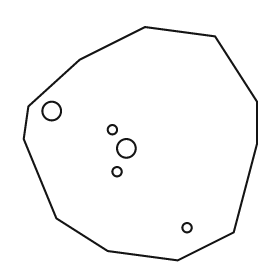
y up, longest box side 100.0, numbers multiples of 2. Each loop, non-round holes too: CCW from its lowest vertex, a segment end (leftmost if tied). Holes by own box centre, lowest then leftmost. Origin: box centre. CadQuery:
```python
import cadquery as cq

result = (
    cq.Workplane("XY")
    .moveTo(16.0, -50.0)
    .lineTo(40.0, -38.0)
    .lineTo(50.0, 0.0)
    .lineTo(50.0, 18.0)
    .lineTo(32.0, 46.0)
    .lineTo(2.0, 50.0)
    .lineTo(-26.0, 36.0)
    .lineTo(-48.0, 16.0)
    .lineTo(-50.0, 2.0)
    .lineTo(-36.0, -32.0)
    .lineTo(-14.0, -46.0)
    .close()
    .moveTo(20.0, -36.0)
    .circle(2.0)
    .moveTo(-10.0, -12.0)
    .circle(2.0)
    .moveTo(-6.0, -2.0)
    .circle(4.0)
    .moveTo(-12.0, 6.0)
    .circle(2.0)
    .moveTo(-38.0, 14.0)
    .circle(4.0)
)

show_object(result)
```